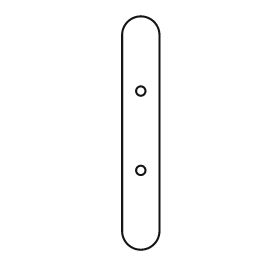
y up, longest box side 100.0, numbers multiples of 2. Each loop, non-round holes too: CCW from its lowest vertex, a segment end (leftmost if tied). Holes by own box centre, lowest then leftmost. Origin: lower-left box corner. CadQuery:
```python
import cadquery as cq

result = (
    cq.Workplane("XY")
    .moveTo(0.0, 8.0)
    .threePointArc((8.0, 0.0), (16.0, 8.0))
    .lineTo(16.0, 92.0)
    .threePointArc((8.0, 100.0), (0.0, 92.0))
    .close()
    .moveTo(8.0, 34.0)
    .circle(2.0)
    .moveTo(8.0, 68.0)
    .circle(2.0)
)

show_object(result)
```